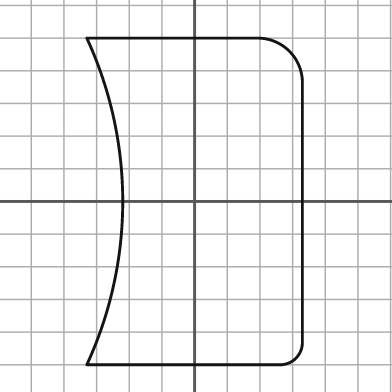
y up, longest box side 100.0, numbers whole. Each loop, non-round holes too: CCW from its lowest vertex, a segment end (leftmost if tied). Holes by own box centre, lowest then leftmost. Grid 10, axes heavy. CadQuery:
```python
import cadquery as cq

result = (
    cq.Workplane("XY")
    .moveTo(-33.0, -50.0)
    .lineTo(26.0, -50.0)
    .threePointArc((31.0, -48.0), (33.0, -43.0))
    .lineTo(33.0, 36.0)
    .threePointArc((29.0, 46.0), (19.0, 50.0))
    .lineTo(-33.0, 50.0)
    .threePointArc((-22.0, 0.0), (-33.0, -50.0))
    .close()
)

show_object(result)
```